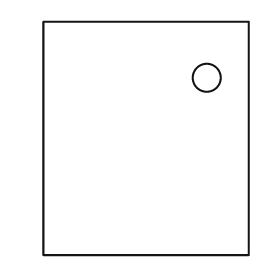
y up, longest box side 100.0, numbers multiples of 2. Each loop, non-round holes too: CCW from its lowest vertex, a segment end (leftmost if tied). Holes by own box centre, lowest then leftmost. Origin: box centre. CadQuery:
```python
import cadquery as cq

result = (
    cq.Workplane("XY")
    .moveTo(-44.0, -50.0)
    .lineTo(44.0, -50.0)
    .lineTo(44.0, 50.0)
    .lineTo(-44.0, 50.0)
    .close()
    .moveTo(26.0, 26.0)
    .circle(6.0)
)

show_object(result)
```